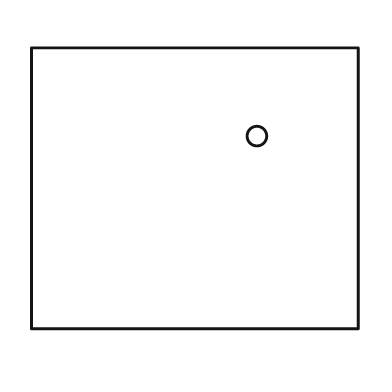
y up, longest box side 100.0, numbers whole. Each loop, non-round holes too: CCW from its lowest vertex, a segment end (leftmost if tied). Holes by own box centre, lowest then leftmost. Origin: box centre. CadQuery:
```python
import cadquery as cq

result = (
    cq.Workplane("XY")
    .moveTo(-50.0, -43.0)
    .lineTo(50.0, -43.0)
    .lineTo(50.0, 43.0)
    .lineTo(-50.0, 43.0)
    .close()
    .moveTo(19.0, 16.0)
    .circle(3.0)
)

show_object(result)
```